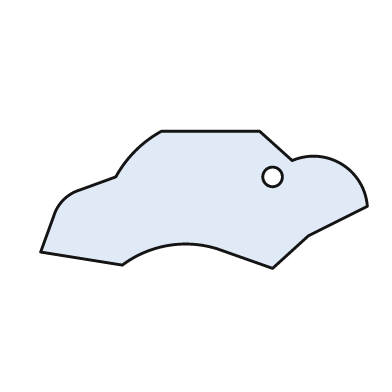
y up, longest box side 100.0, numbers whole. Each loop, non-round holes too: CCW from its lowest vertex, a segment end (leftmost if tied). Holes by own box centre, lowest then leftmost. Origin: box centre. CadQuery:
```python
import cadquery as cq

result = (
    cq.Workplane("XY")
    .moveTo(21.0, -21.0)
    .lineTo(32.0, -11.0)
    .lineTo(50.0, -2.0)
    .threePointArc((42.0, 11.0), (27.0, 12.0))
    .lineTo(17.0, 21.0)
    .lineTo(-13.0, 21.0)
    .threePointArc((-21.0, 15.0), (-27.0, 7.0))
    .lineTo(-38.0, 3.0)
    .threePointArc((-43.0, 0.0), (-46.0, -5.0))
    .lineTo(-50.0, -16.0)
    .lineTo(-25.0, -20.0)
    .threePointArc((-11.0, -14.0), (4.0, -15.0))
    .close()
    .moveTo(21.0, 7.0)
    .circle(3.0)
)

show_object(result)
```